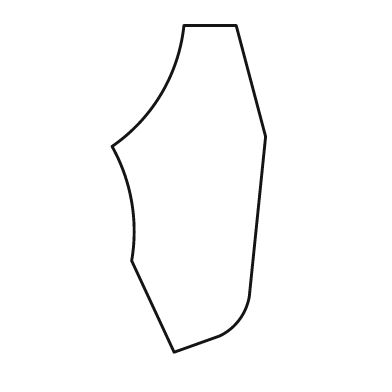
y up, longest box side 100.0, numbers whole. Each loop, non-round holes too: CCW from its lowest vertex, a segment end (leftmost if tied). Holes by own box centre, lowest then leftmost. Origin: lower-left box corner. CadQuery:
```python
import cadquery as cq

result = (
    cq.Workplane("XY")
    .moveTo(19.0, 0.0)
    .lineTo(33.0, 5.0)
    .threePointArc((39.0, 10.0), (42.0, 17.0))
    .lineTo(47.0, 66.0)
    .lineTo(38.0, 100.0)
    .lineTo(22.0, 100.0)
    .threePointArc((15.0, 79.0), (0.0, 63.0))
    .threePointArc((6.0, 46.0), (6.0, 28.0))
    .close()
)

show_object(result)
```